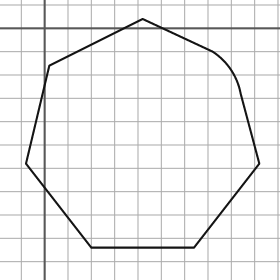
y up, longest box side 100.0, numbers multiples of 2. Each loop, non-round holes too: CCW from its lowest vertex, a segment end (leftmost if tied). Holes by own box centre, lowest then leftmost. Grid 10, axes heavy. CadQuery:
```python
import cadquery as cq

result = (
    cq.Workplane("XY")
    .moveTo(20.0, -94.0)
    .lineTo(64.0, -94.0)
    .lineTo(92.0, -58.0)
    .lineTo(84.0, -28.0)
    .threePointArc((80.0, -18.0), (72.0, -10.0))
    .lineTo(42.0, 4.0)
    .lineTo(2.0, -16.0)
    .lineTo(-8.0, -58.0)
    .close()
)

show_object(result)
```